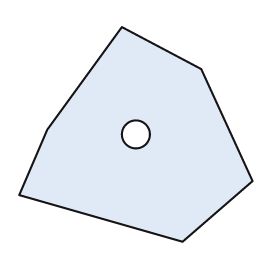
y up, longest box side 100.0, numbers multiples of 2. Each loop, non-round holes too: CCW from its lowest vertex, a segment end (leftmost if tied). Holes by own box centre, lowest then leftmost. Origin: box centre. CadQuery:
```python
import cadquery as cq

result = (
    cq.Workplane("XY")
    .moveTo(20.0, -46.0)
    .lineTo(50.0, -20.0)
    .lineTo(28.0, 28.0)
    .lineTo(-6.0, 46.0)
    .lineTo(-38.0, 2.0)
    .lineTo(-50.0, -26.0)
    .close()
    .moveTo(0.0, 0.0)
    .circle(6.0)
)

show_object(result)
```